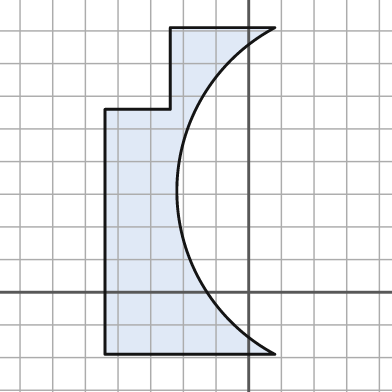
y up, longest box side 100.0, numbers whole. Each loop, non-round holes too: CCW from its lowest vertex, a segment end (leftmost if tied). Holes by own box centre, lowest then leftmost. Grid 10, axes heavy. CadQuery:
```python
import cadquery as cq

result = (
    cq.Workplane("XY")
    .moveTo(-44.0, -19.0)
    .lineTo(8.0, -19.0)
    .threePointArc((-22.0, 31.0), (8.0, 81.0))
    .lineTo(-24.0, 81.0)
    .lineTo(-24.0, 56.0)
    .lineTo(-44.0, 56.0)
    .close()
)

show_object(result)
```